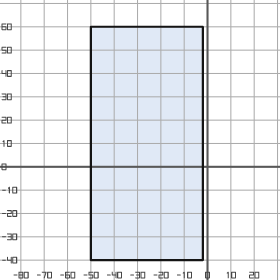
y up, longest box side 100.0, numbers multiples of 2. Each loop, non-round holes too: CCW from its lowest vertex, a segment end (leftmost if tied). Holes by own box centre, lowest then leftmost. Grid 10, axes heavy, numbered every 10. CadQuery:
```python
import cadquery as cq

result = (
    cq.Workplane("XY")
    .moveTo(-50.0, -40.0)
    .lineTo(-2.0, -40.0)
    .lineTo(-2.0, 60.0)
    .lineTo(-50.0, 60.0)
    .close()
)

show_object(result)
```